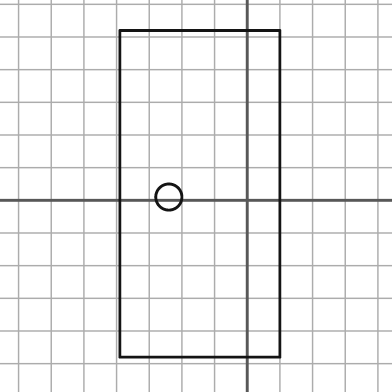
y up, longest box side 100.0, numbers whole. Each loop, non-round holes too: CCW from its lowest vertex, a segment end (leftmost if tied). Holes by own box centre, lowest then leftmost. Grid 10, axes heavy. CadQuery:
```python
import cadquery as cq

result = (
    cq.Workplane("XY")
    .moveTo(-39.0, -48.0)
    .lineTo(10.0, -48.0)
    .lineTo(10.0, 52.0)
    .lineTo(-39.0, 52.0)
    .close()
    .moveTo(-24.0, 1.0)
    .circle(4.0)
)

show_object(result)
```